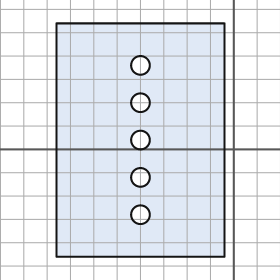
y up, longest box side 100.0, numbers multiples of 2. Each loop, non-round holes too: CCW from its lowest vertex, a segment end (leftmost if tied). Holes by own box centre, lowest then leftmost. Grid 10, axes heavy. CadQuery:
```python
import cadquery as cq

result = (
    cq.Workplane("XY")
    .moveTo(-76.0, -46.0)
    .lineTo(-4.0, -46.0)
    .lineTo(-4.0, 54.0)
    .lineTo(-76.0, 54.0)
    .close()
    .moveTo(-40.0, -28.0)
    .circle(4.0)
    .moveTo(-40.0, -12.0)
    .circle(4.0)
    .moveTo(-40.0, 4.0)
    .circle(4.0)
    .moveTo(-40.0, 20.0)
    .circle(4.0)
    .moveTo(-40.0, 36.0)
    .circle(4.0)
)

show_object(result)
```